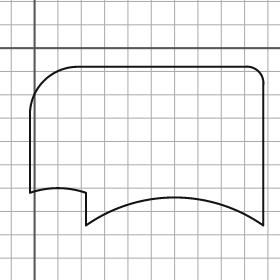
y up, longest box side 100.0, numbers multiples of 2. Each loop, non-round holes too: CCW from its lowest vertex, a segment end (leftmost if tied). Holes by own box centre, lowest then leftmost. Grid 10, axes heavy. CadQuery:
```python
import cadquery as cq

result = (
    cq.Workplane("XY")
    .moveTo(22.0, -76.0)
    .threePointArc((60.0, -64.0), (98.0, -76.0))
    .lineTo(98.0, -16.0)
    .threePointArc((96.0, -10.0), (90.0, -8.0))
    .lineTo(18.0, -8.0)
    .threePointArc((4.0, -14.0), (-2.0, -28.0))
    .lineTo(-2.0, -62.0)
    .threePointArc((10.0, -60.0), (22.0, -62.0))
    .close()
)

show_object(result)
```